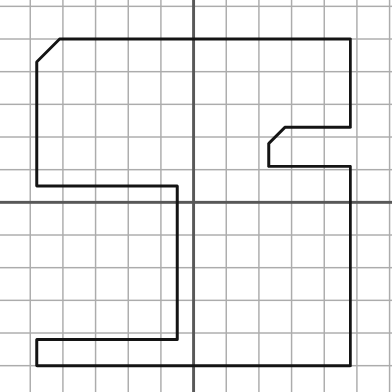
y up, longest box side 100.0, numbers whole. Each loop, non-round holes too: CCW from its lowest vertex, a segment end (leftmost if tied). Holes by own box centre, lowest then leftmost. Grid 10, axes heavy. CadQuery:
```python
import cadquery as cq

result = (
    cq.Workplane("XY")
    .moveTo(-48.0, -50.0)
    .lineTo(48.0, -50.0)
    .lineTo(48.0, 11.0)
    .lineTo(23.0, 11.0)
    .lineTo(23.0, 18.0)
    .lineTo(28.0, 23.0)
    .lineTo(48.0, 23.0)
    .lineTo(48.0, 50.0)
    .lineTo(-41.0, 50.0)
    .lineTo(-48.0, 43.0)
    .lineTo(-48.0, 5.0)
    .lineTo(-5.0, 5.0)
    .lineTo(-5.0, -42.0)
    .lineTo(-48.0, -42.0)
    .close()
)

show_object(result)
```